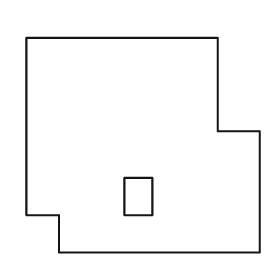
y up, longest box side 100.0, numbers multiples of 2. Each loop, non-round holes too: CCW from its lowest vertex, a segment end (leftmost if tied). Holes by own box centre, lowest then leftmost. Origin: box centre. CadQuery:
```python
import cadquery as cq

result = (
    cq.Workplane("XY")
    .moveTo(-36.0, -46.0)
    .lineTo(50.0, -46.0)
    .lineTo(50.0, 6.0)
    .lineTo(32.0, 6.0)
    .lineTo(32.0, 46.0)
    .lineTo(-50.0, 46.0)
    .lineTo(-50.0, -30.0)
    .lineTo(-36.0, -30.0)
    .close()
    .moveTo(-8.0, -30.0)
    .lineTo(4.0, -30.0)
    .lineTo(4.0, -14.0)
    .lineTo(-8.0, -14.0)
    .close()
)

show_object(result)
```